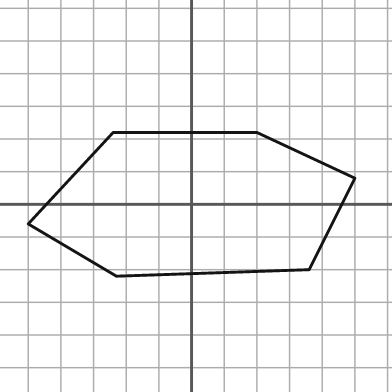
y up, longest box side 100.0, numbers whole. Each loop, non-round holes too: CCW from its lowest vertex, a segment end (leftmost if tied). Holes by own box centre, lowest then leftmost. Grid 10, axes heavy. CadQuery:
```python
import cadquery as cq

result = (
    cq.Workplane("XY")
    .moveTo(-23.0, -22.0)
    .lineTo(36.0, -20.0)
    .lineTo(50.0, 8.0)
    .lineTo(20.0, 22.0)
    .lineTo(-24.0, 22.0)
    .lineTo(-50.0, -6.0)
    .close()
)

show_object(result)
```